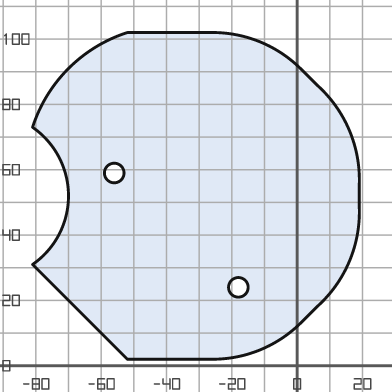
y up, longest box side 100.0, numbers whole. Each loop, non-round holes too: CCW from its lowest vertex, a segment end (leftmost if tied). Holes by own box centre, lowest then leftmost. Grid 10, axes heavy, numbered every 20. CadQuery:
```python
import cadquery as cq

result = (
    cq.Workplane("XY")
    .moveTo(-52.0, 2.0)
    .lineTo(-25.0, 2.0)
    .threePointArc((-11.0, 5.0), (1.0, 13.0))
    .lineTo(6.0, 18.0)
    .threePointArc((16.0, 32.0), (19.0, 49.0))
    .lineTo(19.0, 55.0)
    .threePointArc((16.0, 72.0), (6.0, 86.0))
    .lineTo(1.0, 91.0)
    .threePointArc((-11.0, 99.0), (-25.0, 102.0))
    .lineTo(-52.0, 102.0)
    .threePointArc((-70.0, 91.0), (-81.0, 73.0))
    .threePointArc((-70.0, 52.0), (-81.0, 31.0))
    .close()
    .moveTo(-18.0, 24.0)
    .circle(3.0)
    .moveTo(-56.0, 59.0)
    .circle(3.0)
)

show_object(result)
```